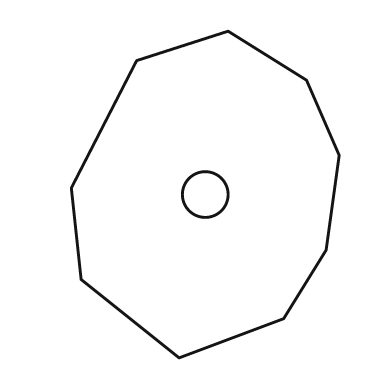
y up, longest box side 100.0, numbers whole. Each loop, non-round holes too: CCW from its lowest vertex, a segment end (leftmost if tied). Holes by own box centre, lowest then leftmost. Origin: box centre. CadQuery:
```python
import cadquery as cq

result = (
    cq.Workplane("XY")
    .moveTo(-8.0, -50.0)
    .lineTo(24.0, -38.0)
    .lineTo(37.0, -17.0)
    .lineTo(41.0, 12.0)
    .lineTo(31.0, 35.0)
    .lineTo(7.0, 50.0)
    .lineTo(-21.0, 41.0)
    .lineTo(-41.0, 2.0)
    .lineTo(-38.0, -26.0)
    .close()
    .moveTo(0.0, 0.0)
    .circle(7.0)
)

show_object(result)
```